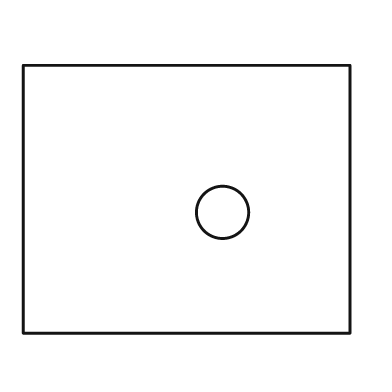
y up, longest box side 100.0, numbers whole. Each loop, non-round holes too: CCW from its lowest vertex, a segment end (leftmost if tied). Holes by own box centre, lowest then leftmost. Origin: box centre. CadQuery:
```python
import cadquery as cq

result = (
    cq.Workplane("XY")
    .moveTo(-50.0, -41.0)
    .lineTo(50.0, -41.0)
    .lineTo(50.0, 41.0)
    .lineTo(-50.0, 41.0)
    .close()
    .moveTo(11.0, -4.0)
    .circle(8.0)
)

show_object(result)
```